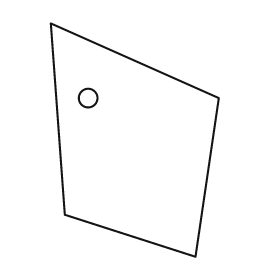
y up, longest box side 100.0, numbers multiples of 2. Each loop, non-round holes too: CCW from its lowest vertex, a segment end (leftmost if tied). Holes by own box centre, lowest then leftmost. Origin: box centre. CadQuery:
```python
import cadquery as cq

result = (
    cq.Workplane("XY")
    .moveTo(26.0, -50.0)
    .lineTo(36.0, 18.0)
    .lineTo(-36.0, 50.0)
    .lineTo(-30.0, -32.0)
    .close()
    .moveTo(-20.0, 18.0)
    .circle(4.0)
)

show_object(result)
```